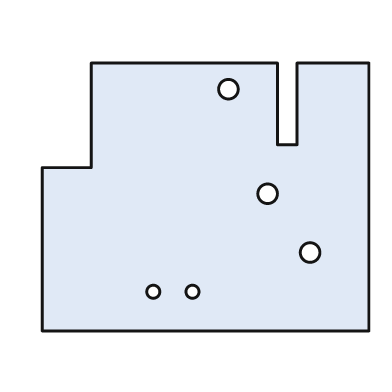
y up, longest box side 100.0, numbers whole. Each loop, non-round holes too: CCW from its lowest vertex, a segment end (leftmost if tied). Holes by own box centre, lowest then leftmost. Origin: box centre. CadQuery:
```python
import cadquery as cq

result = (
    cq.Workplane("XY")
    .moveTo(-50.0, -41.0)
    .lineTo(50.0, -41.0)
    .lineTo(50.0, 41.0)
    .lineTo(28.0, 41.0)
    .lineTo(28.0, 16.0)
    .lineTo(22.0, 16.0)
    .lineTo(22.0, 41.0)
    .lineTo(-35.0, 41.0)
    .lineTo(-35.0, 9.0)
    .lineTo(-50.0, 9.0)
    .close()
    .moveTo(-16.0, -29.0)
    .circle(2.0)
    .moveTo(-4.0, -29.0)
    .circle(2.0)
    .moveTo(32.0, -17.0)
    .circle(3.0)
    .moveTo(19.0, 1.0)
    .circle(3.0)
    .moveTo(7.0, 33.0)
    .circle(3.0)
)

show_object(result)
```